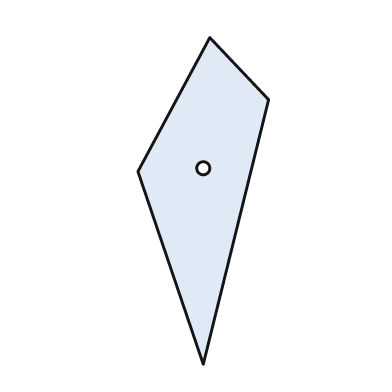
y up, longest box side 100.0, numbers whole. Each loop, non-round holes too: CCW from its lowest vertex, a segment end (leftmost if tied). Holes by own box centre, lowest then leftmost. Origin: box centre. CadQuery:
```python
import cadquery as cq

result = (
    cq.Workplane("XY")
    .moveTo(0.0, -50.0)
    .lineTo(20.0, 31.0)
    .lineTo(2.0, 50.0)
    .lineTo(-20.0, 9.0)
    .close()
    .moveTo(0.0, 10.0)
    .circle(2.0)
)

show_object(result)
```